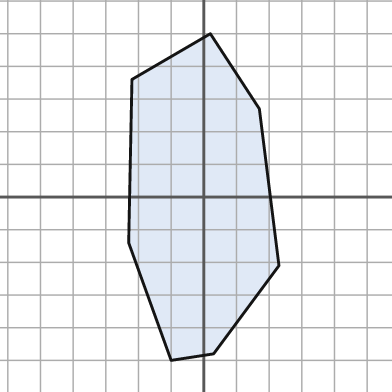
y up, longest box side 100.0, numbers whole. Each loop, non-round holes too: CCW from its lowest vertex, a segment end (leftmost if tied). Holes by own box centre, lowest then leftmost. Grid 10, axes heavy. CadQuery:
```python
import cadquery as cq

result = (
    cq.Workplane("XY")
    .moveTo(-10.0, -50.0)
    .lineTo(3.0, -48.0)
    .lineTo(23.0, -21.0)
    .lineTo(17.0, 27.0)
    .lineTo(2.0, 50.0)
    .lineTo(-22.0, 36.0)
    .lineTo(-23.0, -14.0)
    .close()
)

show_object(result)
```